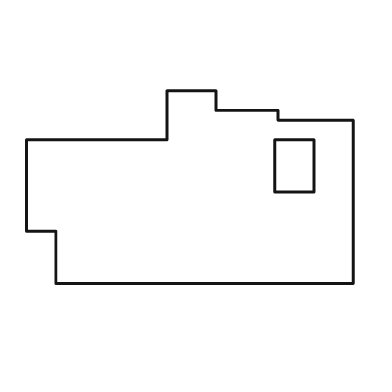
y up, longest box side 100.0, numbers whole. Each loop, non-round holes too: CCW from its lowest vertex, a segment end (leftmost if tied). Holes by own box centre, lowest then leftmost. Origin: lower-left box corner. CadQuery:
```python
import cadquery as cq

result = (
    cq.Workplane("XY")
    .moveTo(9.0, 0.0)
    .lineTo(100.0, 0.0)
    .lineTo(100.0, 50.0)
    .lineTo(77.0, 50.0)
    .lineTo(77.0, 53.0)
    .lineTo(58.0, 53.0)
    .lineTo(58.0, 59.0)
    .lineTo(43.0, 59.0)
    .lineTo(43.0, 44.0)
    .lineTo(0.0, 44.0)
    .lineTo(0.0, 16.0)
    .lineTo(9.0, 16.0)
    .close()
    .moveTo(76.0, 28.0)
    .lineTo(88.0, 28.0)
    .lineTo(88.0, 44.0)
    .lineTo(76.0, 44.0)
    .close()
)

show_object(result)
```